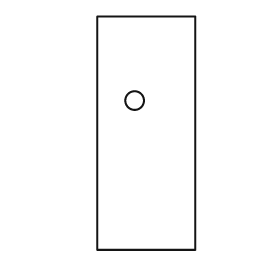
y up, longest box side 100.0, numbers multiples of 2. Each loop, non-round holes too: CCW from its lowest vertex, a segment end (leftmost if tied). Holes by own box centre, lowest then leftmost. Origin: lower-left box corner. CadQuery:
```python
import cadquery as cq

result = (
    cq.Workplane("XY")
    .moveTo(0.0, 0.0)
    .lineTo(42.0, 0.0)
    .lineTo(42.0, 100.0)
    .lineTo(0.0, 100.0)
    .close()
    .moveTo(16.0, 64.0)
    .circle(4.0)
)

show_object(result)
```